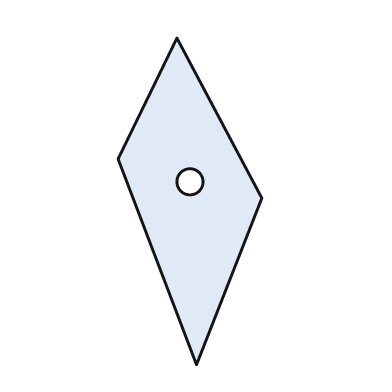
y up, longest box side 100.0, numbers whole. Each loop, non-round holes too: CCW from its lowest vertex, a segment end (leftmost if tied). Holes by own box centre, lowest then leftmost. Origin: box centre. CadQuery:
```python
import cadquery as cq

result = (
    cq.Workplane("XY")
    .moveTo(2.0, -50.0)
    .lineTo(22.0, 1.0)
    .lineTo(-4.0, 50.0)
    .lineTo(-22.0, 13.0)
    .close()
    .moveTo(0.0, 6.0)
    .circle(4.0)
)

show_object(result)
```